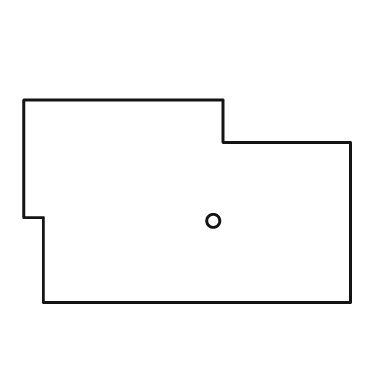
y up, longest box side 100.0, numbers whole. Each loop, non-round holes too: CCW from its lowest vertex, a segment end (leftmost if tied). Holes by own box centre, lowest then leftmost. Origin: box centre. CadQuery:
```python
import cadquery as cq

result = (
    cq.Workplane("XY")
    .moveTo(-44.0, -31.0)
    .lineTo(50.0, -31.0)
    .lineTo(50.0, 18.0)
    .lineTo(11.0, 18.0)
    .lineTo(11.0, 31.0)
    .lineTo(-50.0, 31.0)
    .lineTo(-50.0, -5.0)
    .lineTo(-44.0, -5.0)
    .close()
    .moveTo(8.0, -6.0)
    .circle(2.0)
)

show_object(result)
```